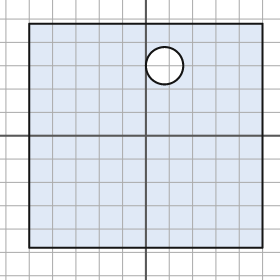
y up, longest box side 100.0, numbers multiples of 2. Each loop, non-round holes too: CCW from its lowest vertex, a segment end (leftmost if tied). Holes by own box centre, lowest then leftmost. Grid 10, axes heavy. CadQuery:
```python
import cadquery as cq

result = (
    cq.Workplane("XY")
    .moveTo(-50.0, -48.0)
    .lineTo(50.0, -48.0)
    .lineTo(50.0, 48.0)
    .lineTo(-50.0, 48.0)
    .close()
    .moveTo(8.0, 30.0)
    .circle(8.0)
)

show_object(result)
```